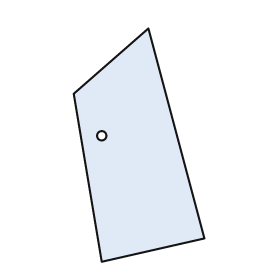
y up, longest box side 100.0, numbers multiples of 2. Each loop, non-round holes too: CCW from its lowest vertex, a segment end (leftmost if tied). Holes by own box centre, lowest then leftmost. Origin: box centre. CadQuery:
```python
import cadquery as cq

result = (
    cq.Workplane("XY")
    .moveTo(-16.0, -50.0)
    .lineTo(28.0, -40.0)
    .lineTo(4.0, 50.0)
    .lineTo(-28.0, 22.0)
    .close()
    .moveTo(-16.0, 4.0)
    .circle(2.0)
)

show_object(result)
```